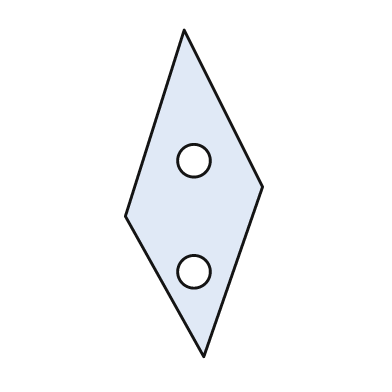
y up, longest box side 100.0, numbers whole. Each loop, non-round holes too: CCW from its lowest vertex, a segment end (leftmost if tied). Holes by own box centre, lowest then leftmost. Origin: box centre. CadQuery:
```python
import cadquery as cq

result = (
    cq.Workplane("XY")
    .moveTo(3.0, -50.0)
    .lineTo(21.0, 2.0)
    .lineTo(-3.0, 50.0)
    .lineTo(-21.0, -7.0)
    .close()
    .moveTo(0.0, -24.0)
    .circle(5.0)
    .moveTo(0.0, 10.0)
    .circle(5.0)
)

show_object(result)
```